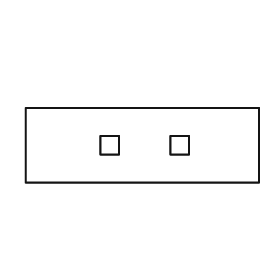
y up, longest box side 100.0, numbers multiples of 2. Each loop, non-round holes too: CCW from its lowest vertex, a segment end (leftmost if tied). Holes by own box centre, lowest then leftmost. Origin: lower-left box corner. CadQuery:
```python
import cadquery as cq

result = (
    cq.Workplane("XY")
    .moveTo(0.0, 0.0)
    .lineTo(100.0, 0.0)
    .lineTo(100.0, 32.0)
    .lineTo(0.0, 32.0)
    .close()
    .moveTo(32.0, 12.0)
    .lineTo(40.0, 12.0)
    .lineTo(40.0, 20.0)
    .lineTo(32.0, 20.0)
    .close()
    .moveTo(62.0, 12.0)
    .lineTo(70.0, 12.0)
    .lineTo(70.0, 20.0)
    .lineTo(62.0, 20.0)
    .close()
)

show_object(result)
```